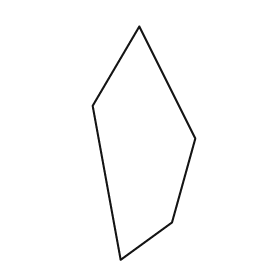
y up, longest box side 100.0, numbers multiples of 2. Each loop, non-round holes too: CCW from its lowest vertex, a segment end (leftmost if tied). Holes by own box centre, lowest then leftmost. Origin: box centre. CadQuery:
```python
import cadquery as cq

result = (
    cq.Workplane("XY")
    .moveTo(-10.0, -50.0)
    .lineTo(12.0, -34.0)
    .lineTo(22.0, 2.0)
    .lineTo(-2.0, 50.0)
    .lineTo(-22.0, 16.0)
    .close()
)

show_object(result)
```